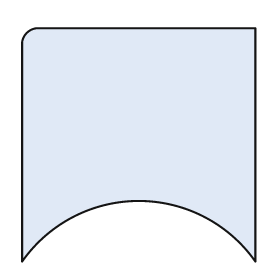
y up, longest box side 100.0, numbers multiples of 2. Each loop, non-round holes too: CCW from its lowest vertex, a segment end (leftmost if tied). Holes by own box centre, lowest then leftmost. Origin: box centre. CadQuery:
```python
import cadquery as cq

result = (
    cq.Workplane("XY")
    .moveTo(-50.0, -50.0)
    .threePointArc((0.0, -24.0), (50.0, -50.0))
    .lineTo(50.0, 50.0)
    .lineTo(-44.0, 50.0)
    .threePointArc((-48.0, 48.0), (-50.0, 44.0))
    .close()
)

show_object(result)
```